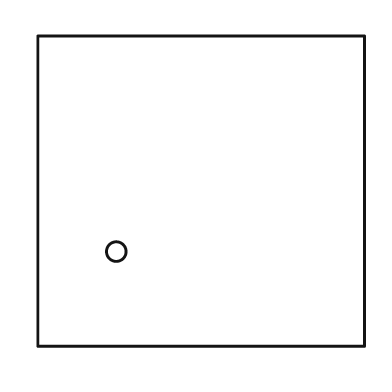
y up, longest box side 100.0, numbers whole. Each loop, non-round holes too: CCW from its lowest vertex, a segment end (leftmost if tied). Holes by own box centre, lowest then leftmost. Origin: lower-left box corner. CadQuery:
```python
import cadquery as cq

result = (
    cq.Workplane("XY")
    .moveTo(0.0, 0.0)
    .lineTo(100.0, 0.0)
    .lineTo(100.0, 95.0)
    .lineTo(0.0, 95.0)
    .close()
    .moveTo(24.0, 29.0)
    .circle(3.0)
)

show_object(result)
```